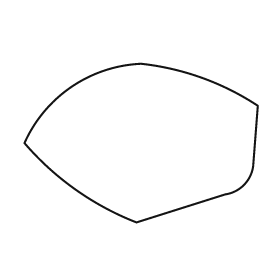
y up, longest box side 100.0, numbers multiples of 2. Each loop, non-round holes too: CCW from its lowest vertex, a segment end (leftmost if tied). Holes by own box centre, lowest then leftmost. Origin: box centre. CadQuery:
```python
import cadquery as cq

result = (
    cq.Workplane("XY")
    .moveTo(-2.0, -34.0)
    .lineTo(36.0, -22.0)
    .threePointArc((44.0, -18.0), (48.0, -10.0))
    .lineTo(50.0, 16.0)
    .threePointArc((26.0, 28.0), (0.0, 34.0))
    .threePointArc((-30.0, 24.0), (-50.0, 0.0))
    .threePointArc((-28.0, -20.0), (-2.0, -34.0))
    .close()
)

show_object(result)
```